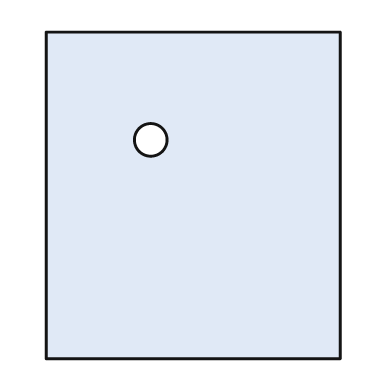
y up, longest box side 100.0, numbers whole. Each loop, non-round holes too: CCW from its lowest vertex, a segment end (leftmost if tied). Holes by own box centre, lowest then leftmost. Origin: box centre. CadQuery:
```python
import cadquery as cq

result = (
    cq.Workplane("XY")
    .moveTo(-45.0, -50.0)
    .lineTo(45.0, -50.0)
    .lineTo(45.0, 50.0)
    .lineTo(-45.0, 50.0)
    .close()
    .moveTo(-13.0, 17.0)
    .circle(5.0)
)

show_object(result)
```